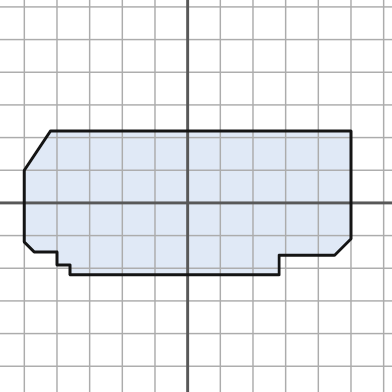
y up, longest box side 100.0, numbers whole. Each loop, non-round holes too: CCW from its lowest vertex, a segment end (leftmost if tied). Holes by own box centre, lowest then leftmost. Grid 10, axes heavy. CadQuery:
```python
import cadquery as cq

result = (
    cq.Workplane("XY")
    .moveTo(-36.0, -22.0)
    .lineTo(28.0, -22.0)
    .lineTo(28.0, -16.0)
    .lineTo(45.0, -16.0)
    .lineTo(50.0, -11.0)
    .lineTo(50.0, 22.0)
    .lineTo(-42.0, 22.0)
    .lineTo(-50.0, 10.0)
    .lineTo(-50.0, -12.0)
    .lineTo(-47.0, -15.0)
    .lineTo(-40.0, -15.0)
    .lineTo(-40.0, -19.0)
    .lineTo(-36.0, -19.0)
    .close()
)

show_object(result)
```